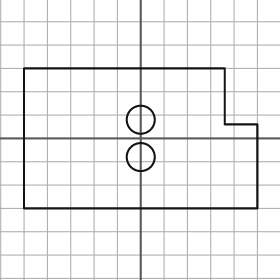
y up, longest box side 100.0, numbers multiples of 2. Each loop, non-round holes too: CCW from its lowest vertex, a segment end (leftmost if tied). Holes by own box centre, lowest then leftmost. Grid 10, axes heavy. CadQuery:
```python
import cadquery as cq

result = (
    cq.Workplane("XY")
    .moveTo(-50.0, -30.0)
    .lineTo(50.0, -30.0)
    .lineTo(50.0, 6.0)
    .lineTo(36.0, 6.0)
    .lineTo(36.0, 30.0)
    .lineTo(-50.0, 30.0)
    .close()
    .moveTo(0.0, -8.0)
    .circle(6.0)
    .moveTo(0.0, 8.0)
    .circle(6.0)
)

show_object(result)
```